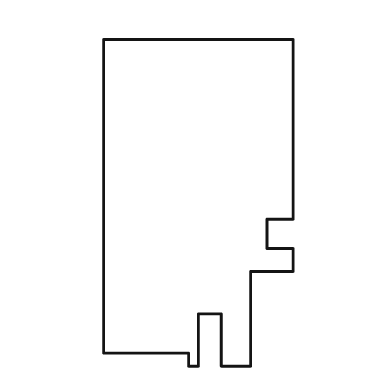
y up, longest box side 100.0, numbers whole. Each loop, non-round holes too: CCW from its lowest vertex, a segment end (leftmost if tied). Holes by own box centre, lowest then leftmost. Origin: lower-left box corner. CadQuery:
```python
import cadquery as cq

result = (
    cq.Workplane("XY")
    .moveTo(26.0, 0.0)
    .lineTo(29.0, 0.0)
    .lineTo(29.0, 16.0)
    .lineTo(36.0, 16.0)
    .lineTo(36.0, 0.0)
    .lineTo(45.0, 0.0)
    .lineTo(45.0, 29.0)
    .lineTo(58.0, 29.0)
    .lineTo(58.0, 36.0)
    .lineTo(50.0, 36.0)
    .lineTo(50.0, 45.0)
    .lineTo(58.0, 45.0)
    .lineTo(58.0, 100.0)
    .lineTo(0.0, 100.0)
    .lineTo(0.0, 4.0)
    .lineTo(26.0, 4.0)
    .close()
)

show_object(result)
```